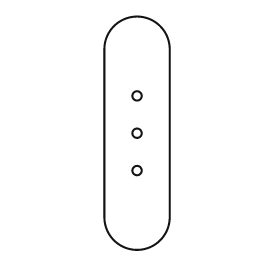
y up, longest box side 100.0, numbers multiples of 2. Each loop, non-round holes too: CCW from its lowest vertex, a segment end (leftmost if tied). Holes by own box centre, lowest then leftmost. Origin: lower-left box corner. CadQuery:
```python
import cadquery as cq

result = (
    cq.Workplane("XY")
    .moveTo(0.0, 14.0)
    .threePointArc((14.0, 0.0), (28.0, 14.0))
    .lineTo(28.0, 86.0)
    .threePointArc((14.0, 100.0), (0.0, 86.0))
    .close()
    .moveTo(14.0, 34.0)
    .circle(2.0)
    .moveTo(14.0, 50.0)
    .circle(2.0)
    .moveTo(14.0, 66.0)
    .circle(2.0)
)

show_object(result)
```